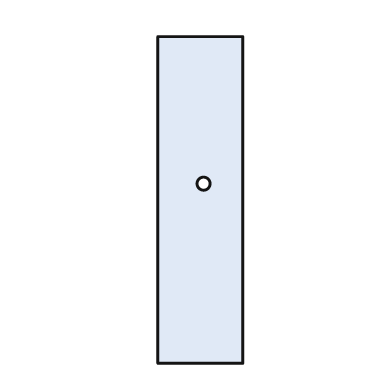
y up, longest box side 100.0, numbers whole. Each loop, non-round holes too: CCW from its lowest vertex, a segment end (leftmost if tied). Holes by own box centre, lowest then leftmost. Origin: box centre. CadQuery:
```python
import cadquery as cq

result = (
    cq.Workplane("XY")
    .moveTo(-13.0, -50.0)
    .lineTo(13.0, -50.0)
    .lineTo(13.0, 50.0)
    .lineTo(-13.0, 50.0)
    .close()
    .moveTo(1.0, 5.0)
    .circle(2.0)
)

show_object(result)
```